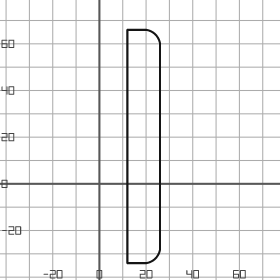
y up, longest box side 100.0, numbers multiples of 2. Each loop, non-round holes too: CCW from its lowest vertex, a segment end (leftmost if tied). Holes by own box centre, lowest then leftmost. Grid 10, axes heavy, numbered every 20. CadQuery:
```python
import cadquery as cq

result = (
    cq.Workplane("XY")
    .moveTo(12.0, -34.0)
    .lineTo(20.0, -34.0)
    .threePointArc((24.0, -32.0), (26.0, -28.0))
    .lineTo(26.0, 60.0)
    .threePointArc((24.0, 64.0), (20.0, 66.0))
    .lineTo(12.0, 66.0)
    .close()
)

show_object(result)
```